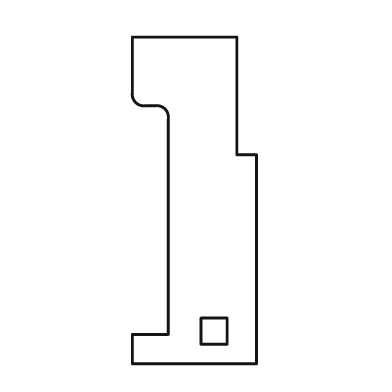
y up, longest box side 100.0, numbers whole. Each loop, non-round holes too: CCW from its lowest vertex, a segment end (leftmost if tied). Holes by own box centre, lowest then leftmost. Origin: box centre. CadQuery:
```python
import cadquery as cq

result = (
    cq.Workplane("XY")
    .moveTo(-19.0, -50.0)
    .lineTo(19.0, -50.0)
    .lineTo(19.0, 14.0)
    .lineTo(13.0, 14.0)
    .lineTo(13.0, 50.0)
    .lineTo(-19.0, 50.0)
    .lineTo(-19.0, 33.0)
    .threePointArc((-18.0, 30.0), (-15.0, 29.0))
    .lineTo(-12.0, 29.0)
    .threePointArc((-9.0, 28.0), (-8.0, 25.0))
    .lineTo(-8.0, -41.0)
    .lineTo(-19.0, -41.0)
    .close()
    .moveTo(2.0, -44.0)
    .lineTo(10.0, -44.0)
    .lineTo(10.0, -36.0)
    .lineTo(2.0, -36.0)
    .close()
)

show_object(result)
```